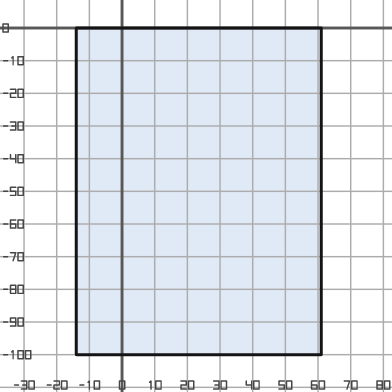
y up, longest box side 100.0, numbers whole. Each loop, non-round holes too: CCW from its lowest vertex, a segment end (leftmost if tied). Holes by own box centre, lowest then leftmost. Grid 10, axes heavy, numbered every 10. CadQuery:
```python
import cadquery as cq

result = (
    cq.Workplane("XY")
    .moveTo(-14.0, -100.0)
    .lineTo(61.0, -100.0)
    .lineTo(61.0, 0.0)
    .lineTo(-14.0, 0.0)
    .close()
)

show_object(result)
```